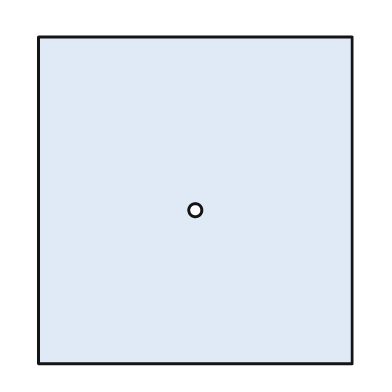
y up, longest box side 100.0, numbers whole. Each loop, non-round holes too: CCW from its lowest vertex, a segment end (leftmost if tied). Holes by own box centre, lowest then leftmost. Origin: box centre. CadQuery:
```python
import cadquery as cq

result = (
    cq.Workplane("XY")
    .moveTo(-48.0, -50.0)
    .lineTo(48.0, -50.0)
    .lineTo(48.0, 50.0)
    .lineTo(-48.0, 50.0)
    .close()
    .moveTo(0.0, -3.0)
    .circle(2.0)
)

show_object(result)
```